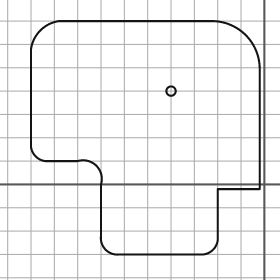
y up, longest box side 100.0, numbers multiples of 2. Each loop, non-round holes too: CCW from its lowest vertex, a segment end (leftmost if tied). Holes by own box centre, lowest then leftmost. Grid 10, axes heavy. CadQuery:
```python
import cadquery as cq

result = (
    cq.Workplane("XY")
    .moveTo(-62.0, -30.0)
    .lineTo(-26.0, -30.0)
    .threePointArc((-22.0, -28.0), (-20.0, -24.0))
    .lineTo(-20.0, -2.0)
    .lineTo(-2.0, -2.0)
    .lineTo(-2.0, 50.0)
    .threePointArc((-8.0, 64.0), (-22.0, 70.0))
    .lineTo(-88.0, 70.0)
    .threePointArc((-96.0, 66.0), (-100.0, 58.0))
    .lineTo(-100.0, 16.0)
    .threePointArc((-98.0, 12.0), (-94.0, 10.0))
    .lineTo(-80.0, 10.0)
    .threePointArc((-72.0, 8.0), (-70.0, 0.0))
    .lineTo(-70.0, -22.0)
    .threePointArc((-68.0, -28.0), (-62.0, -30.0))
    .close()
    .moveTo(-40.0, 40.0)
    .circle(2.0)
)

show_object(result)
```